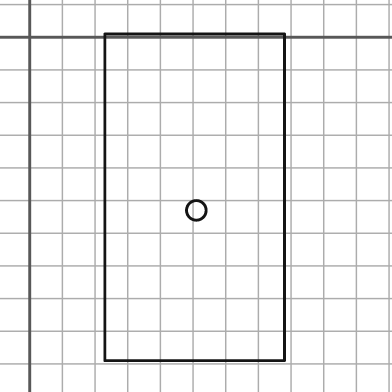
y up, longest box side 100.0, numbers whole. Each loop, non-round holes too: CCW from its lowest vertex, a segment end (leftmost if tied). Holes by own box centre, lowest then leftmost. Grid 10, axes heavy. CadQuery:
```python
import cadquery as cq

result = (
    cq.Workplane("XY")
    .moveTo(23.0, -99.0)
    .lineTo(78.0, -99.0)
    .lineTo(78.0, 1.0)
    .lineTo(23.0, 1.0)
    .close()
    .moveTo(51.0, -53.0)
    .circle(3.0)
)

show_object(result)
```